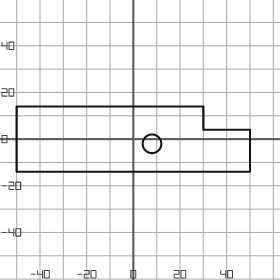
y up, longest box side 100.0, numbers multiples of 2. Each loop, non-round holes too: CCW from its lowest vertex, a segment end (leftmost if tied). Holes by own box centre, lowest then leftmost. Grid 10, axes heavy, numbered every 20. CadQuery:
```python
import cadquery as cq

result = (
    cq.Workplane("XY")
    .moveTo(-50.0, -14.0)
    .lineTo(50.0, -14.0)
    .lineTo(50.0, 4.0)
    .lineTo(30.0, 4.0)
    .lineTo(30.0, 14.0)
    .lineTo(-50.0, 14.0)
    .close()
    .moveTo(8.0, -2.0)
    .circle(4.0)
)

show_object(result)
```